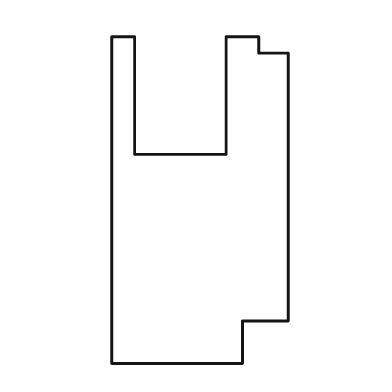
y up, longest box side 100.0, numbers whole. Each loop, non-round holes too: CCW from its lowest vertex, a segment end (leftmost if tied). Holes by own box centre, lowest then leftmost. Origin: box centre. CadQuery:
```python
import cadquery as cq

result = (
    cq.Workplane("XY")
    .moveTo(-27.0, -50.0)
    .lineTo(13.0, -50.0)
    .lineTo(13.0, -37.0)
    .lineTo(27.0, -37.0)
    .lineTo(27.0, 45.0)
    .lineTo(18.0, 45.0)
    .lineTo(18.0, 50.0)
    .lineTo(8.0, 50.0)
    .lineTo(8.0, 14.0)
    .lineTo(-20.0, 14.0)
    .lineTo(-20.0, 50.0)
    .lineTo(-27.0, 50.0)
    .close()
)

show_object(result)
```